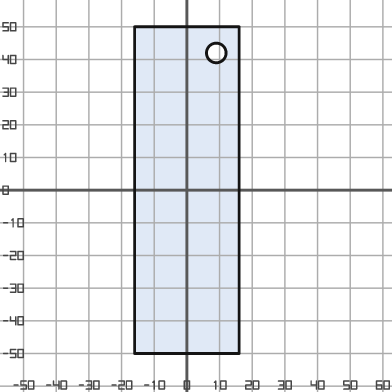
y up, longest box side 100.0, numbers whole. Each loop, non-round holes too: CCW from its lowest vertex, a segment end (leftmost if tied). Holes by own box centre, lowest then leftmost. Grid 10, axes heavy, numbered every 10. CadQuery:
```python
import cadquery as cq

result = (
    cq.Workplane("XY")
    .moveTo(-16.0, -50.0)
    .lineTo(16.0, -50.0)
    .lineTo(16.0, 50.0)
    .lineTo(-16.0, 50.0)
    .close()
    .moveTo(9.0, 42.0)
    .circle(3.0)
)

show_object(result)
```